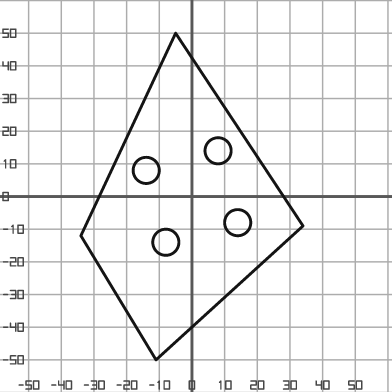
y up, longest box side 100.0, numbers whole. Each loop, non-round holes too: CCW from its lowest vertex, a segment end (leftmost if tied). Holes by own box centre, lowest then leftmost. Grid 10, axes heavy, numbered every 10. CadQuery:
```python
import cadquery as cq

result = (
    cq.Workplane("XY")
    .moveTo(-11.0, -50.0)
    .lineTo(34.0, -9.0)
    .lineTo(-5.0, 50.0)
    .lineTo(-34.0, -12.0)
    .close()
    .moveTo(-8.0, -14.0)
    .circle(4.0)
    .moveTo(14.0, -8.0)
    .circle(4.0)
    .moveTo(-14.0, 8.0)
    .circle(4.0)
    .moveTo(8.0, 14.0)
    .circle(4.0)
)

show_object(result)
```